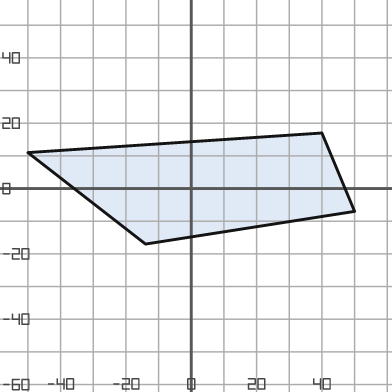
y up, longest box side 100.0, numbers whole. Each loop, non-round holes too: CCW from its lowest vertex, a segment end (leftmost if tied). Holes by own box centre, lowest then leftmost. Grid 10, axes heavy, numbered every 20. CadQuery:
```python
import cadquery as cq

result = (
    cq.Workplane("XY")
    .moveTo(-14.0, -17.0)
    .lineTo(50.0, -7.0)
    .lineTo(40.0, 17.0)
    .lineTo(-50.0, 11.0)
    .close()
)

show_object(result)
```